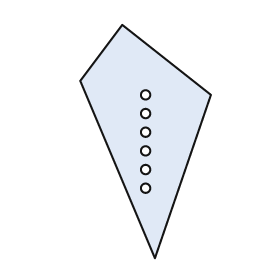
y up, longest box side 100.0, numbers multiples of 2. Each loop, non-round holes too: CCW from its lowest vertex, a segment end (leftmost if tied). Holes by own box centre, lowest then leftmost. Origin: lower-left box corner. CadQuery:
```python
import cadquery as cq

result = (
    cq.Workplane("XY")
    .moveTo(32.0, 0.0)
    .lineTo(56.0, 70.0)
    .lineTo(18.0, 100.0)
    .lineTo(0.0, 76.0)
    .close()
    .moveTo(28.0, 30.0)
    .circle(2.0)
    .moveTo(28.0, 38.0)
    .circle(2.0)
    .moveTo(28.0, 46.0)
    .circle(2.0)
    .moveTo(28.0, 54.0)
    .circle(2.0)
    .moveTo(28.0, 62.0)
    .circle(2.0)
    .moveTo(28.0, 70.0)
    .circle(2.0)
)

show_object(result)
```